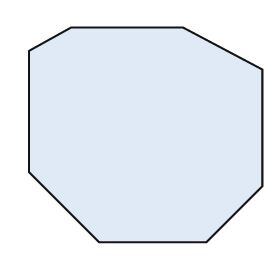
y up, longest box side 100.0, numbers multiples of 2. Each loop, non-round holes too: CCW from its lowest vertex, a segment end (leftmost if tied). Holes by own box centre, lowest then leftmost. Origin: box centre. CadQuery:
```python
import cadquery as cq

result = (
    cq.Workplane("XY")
    .moveTo(-20.0, -46.0)
    .lineTo(26.0, -46.0)
    .lineTo(50.0, -22.0)
    .lineTo(50.0, 28.0)
    .lineTo(16.0, 46.0)
    .lineTo(-32.0, 46.0)
    .lineTo(-50.0, 36.0)
    .lineTo(-50.0, -16.0)
    .close()
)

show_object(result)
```